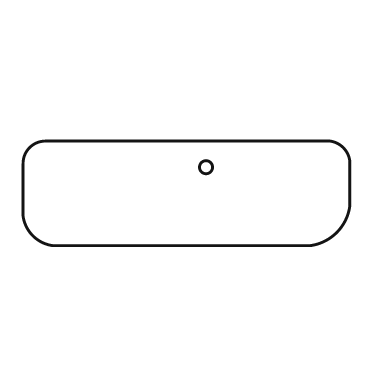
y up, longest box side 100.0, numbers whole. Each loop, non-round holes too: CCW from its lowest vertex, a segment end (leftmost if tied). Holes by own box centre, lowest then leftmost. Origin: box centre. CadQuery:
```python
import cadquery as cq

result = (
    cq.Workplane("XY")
    .moveTo(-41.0, -16.0)
    .lineTo(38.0, -16.0)
    .threePointArc((46.0, -12.0), (50.0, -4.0))
    .lineTo(50.0, 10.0)
    .threePointArc((48.0, 14.0), (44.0, 16.0))
    .lineTo(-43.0, 16.0)
    .threePointArc((-48.0, 14.0), (-50.0, 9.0))
    .lineTo(-50.0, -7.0)
    .threePointArc((-47.0, -13.0), (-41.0, -16.0))
    .close()
    .moveTo(6.0, 8.0)
    .circle(2.0)
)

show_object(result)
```